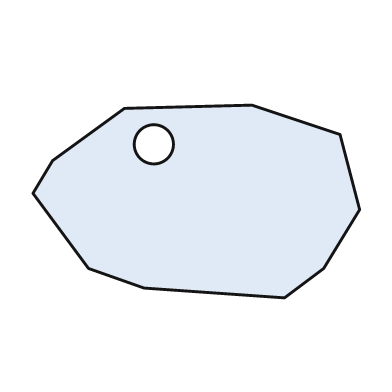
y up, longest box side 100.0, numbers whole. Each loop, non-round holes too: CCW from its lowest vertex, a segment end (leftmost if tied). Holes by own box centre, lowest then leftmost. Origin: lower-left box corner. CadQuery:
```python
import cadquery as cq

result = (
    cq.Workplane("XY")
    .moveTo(77.0, 0.0)
    .lineTo(89.0, 9.0)
    .lineTo(100.0, 27.0)
    .lineTo(94.0, 50.0)
    .lineTo(67.0, 59.0)
    .lineTo(28.0, 58.0)
    .lineTo(6.0, 42.0)
    .lineTo(0.0, 32.0)
    .lineTo(17.0, 9.0)
    .lineTo(34.0, 3.0)
    .close()
    .moveTo(37.0, 47.0)
    .circle(6.0)
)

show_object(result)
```